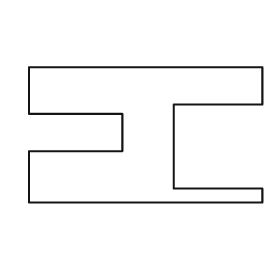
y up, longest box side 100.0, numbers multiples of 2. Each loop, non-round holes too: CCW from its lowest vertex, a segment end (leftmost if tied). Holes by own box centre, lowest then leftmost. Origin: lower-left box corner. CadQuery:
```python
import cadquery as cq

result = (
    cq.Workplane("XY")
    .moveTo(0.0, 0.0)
    .lineTo(100.0, 0.0)
    .lineTo(100.0, 6.0)
    .lineTo(62.0, 6.0)
    .lineTo(62.0, 42.0)
    .lineTo(100.0, 42.0)
    .lineTo(100.0, 58.0)
    .lineTo(0.0, 58.0)
    .lineTo(0.0, 38.0)
    .lineTo(40.0, 38.0)
    .lineTo(40.0, 22.0)
    .lineTo(0.0, 22.0)
    .close()
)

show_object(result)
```